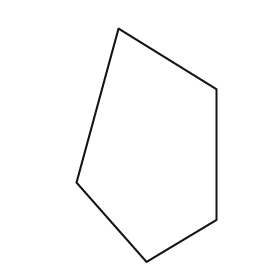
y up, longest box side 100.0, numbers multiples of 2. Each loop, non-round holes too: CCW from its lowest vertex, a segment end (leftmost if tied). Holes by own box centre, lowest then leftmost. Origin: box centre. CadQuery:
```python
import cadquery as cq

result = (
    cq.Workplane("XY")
    .moveTo(0.0, -50.0)
    .lineTo(30.0, -32.0)
    .lineTo(30.0, 24.0)
    .lineTo(-12.0, 50.0)
    .lineTo(-30.0, -16.0)
    .close()
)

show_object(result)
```